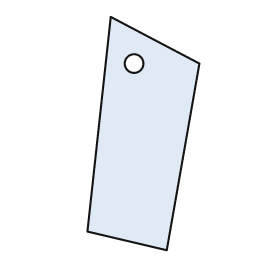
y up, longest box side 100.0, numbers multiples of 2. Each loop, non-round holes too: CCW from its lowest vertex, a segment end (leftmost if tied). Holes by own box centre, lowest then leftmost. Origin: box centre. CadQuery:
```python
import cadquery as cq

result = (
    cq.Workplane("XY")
    .moveTo(10.0, -50.0)
    .lineTo(24.0, 30.0)
    .lineTo(-14.0, 50.0)
    .lineTo(-24.0, -42.0)
    .close()
    .moveTo(-4.0, 30.0)
    .circle(4.0)
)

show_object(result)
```